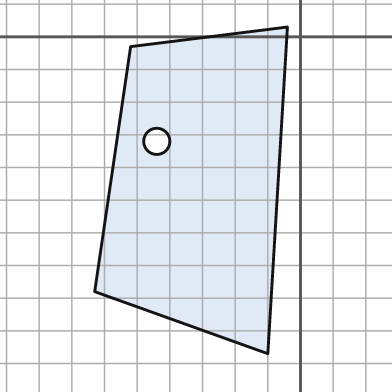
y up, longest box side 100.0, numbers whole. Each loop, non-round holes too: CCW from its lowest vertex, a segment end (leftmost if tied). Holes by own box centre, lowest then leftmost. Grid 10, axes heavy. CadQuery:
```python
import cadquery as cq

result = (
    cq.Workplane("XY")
    .moveTo(-10.0, -97.0)
    .lineTo(-4.0, 3.0)
    .lineTo(-52.0, -3.0)
    .lineTo(-63.0, -78.0)
    .close()
    .moveTo(-44.0, -32.0)
    .circle(4.0)
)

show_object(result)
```